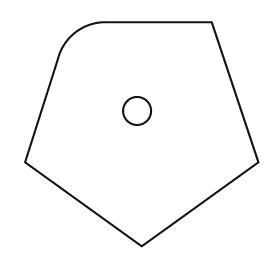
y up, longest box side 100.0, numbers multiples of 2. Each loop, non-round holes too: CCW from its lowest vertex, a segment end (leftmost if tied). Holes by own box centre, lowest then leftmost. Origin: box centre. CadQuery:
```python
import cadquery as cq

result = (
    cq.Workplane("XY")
    .moveTo(0.0, -48.0)
    .lineTo(50.0, -12.0)
    .lineTo(30.0, 48.0)
    .lineTo(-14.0, 48.0)
    .threePointArc((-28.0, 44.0), (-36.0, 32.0))
    .lineTo(-50.0, -12.0)
    .close()
    .moveTo(-2.0, 10.0)
    .circle(6.0)
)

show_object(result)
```